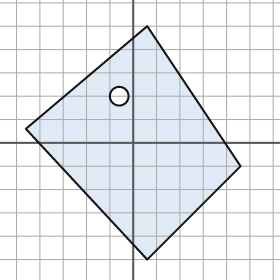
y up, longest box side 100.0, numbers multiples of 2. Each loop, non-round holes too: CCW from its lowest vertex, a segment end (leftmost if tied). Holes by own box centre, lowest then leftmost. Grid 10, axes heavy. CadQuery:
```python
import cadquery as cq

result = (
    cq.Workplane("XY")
    .moveTo(6.0, -50.0)
    .lineTo(46.0, -10.0)
    .lineTo(6.0, 50.0)
    .lineTo(-46.0, 6.0)
    .close()
    .moveTo(-6.0, 20.0)
    .circle(4.0)
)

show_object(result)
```